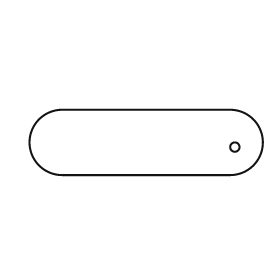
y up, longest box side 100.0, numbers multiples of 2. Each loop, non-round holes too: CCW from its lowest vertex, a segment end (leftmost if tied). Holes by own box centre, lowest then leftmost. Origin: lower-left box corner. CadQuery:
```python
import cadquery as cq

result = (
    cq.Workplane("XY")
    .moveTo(14.0, 0.0)
    .lineTo(86.0, 0.0)
    .threePointArc((100.0, 14.0), (86.0, 28.0))
    .lineTo(14.0, 28.0)
    .threePointArc((0.0, 14.0), (14.0, 0.0))
    .close()
    .moveTo(88.0, 12.0)
    .circle(2.0)
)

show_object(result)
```